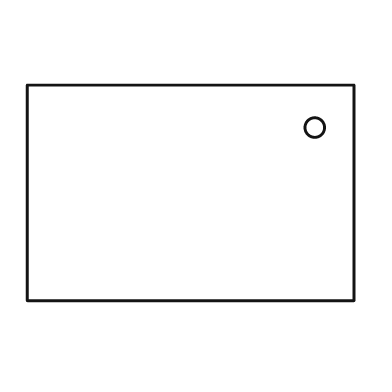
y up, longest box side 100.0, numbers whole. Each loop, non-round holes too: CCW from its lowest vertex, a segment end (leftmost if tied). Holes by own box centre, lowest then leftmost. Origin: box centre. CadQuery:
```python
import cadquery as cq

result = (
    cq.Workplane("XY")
    .moveTo(-50.0, -33.0)
    .lineTo(50.0, -33.0)
    .lineTo(50.0, 33.0)
    .lineTo(-50.0, 33.0)
    .close()
    .moveTo(38.0, 20.0)
    .circle(3.0)
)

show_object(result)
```